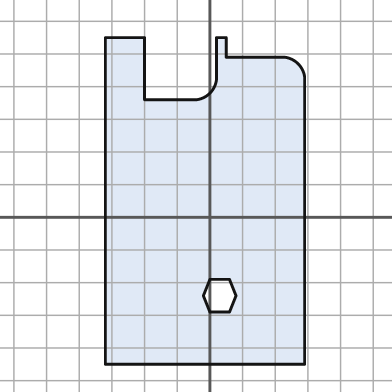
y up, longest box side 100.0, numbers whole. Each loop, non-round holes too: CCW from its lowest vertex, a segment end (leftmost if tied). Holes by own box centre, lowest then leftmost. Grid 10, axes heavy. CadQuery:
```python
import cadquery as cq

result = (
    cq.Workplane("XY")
    .moveTo(-32.0, -45.0)
    .lineTo(29.0, -45.0)
    .lineTo(29.0, 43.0)
    .threePointArc((27.0, 47.0), (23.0, 49.0))
    .lineTo(5.0, 49.0)
    .lineTo(5.0, 55.0)
    .lineTo(2.0, 55.0)
    .lineTo(2.0, 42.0)
    .threePointArc((0.0, 38.0), (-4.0, 36.0))
    .lineTo(-20.0, 36.0)
    .lineTo(-20.0, 55.0)
    .lineTo(-32.0, 55.0)
    .close()
    .moveTo(0.0, -29.0)
    .lineTo(6.0, -29.0)
    .lineTo(8.0, -24.0)
    .lineTo(6.0, -19.0)
    .lineTo(0.0, -19.0)
    .lineTo(-2.0, -24.0)
    .close()
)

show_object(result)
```